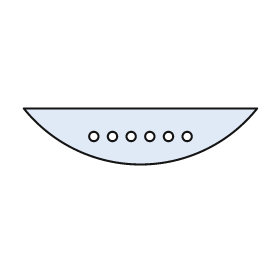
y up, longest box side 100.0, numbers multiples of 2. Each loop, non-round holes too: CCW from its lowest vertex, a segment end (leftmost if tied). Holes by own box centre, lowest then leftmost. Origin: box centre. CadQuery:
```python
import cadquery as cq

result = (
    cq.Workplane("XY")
    .moveTo(-50.0, 12.0)
    .threePointArc((0.0, -12.0), (50.0, 12.0))
    .close()
    .moveTo(-20.0, 0.0)
    .circle(2.0)
    .moveTo(-12.0, 0.0)
    .circle(2.0)
    .moveTo(-4.0, 0.0)
    .circle(2.0)
    .moveTo(4.0, 0.0)
    .circle(2.0)
    .moveTo(12.0, 0.0)
    .circle(2.0)
    .moveTo(20.0, 0.0)
    .circle(2.0)
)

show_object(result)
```